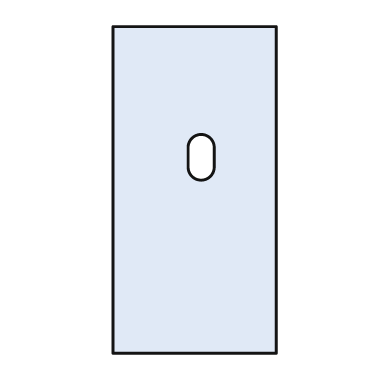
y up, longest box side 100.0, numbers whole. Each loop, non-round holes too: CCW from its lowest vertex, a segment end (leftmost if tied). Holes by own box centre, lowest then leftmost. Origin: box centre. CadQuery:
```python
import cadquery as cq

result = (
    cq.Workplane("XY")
    .moveTo(-25.0, -50.0)
    .lineTo(25.0, -50.0)
    .lineTo(25.0, 50.0)
    .lineTo(-25.0, 50.0)
    .close()
    .moveTo(-2.0, 7.0)
    .threePointArc((2.0, 3.0), (6.0, 7.0))
    .lineTo(6.0, 13.0)
    .threePointArc((2.0, 17.0), (-2.0, 13.0))
    .close()
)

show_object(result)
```